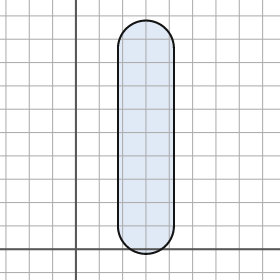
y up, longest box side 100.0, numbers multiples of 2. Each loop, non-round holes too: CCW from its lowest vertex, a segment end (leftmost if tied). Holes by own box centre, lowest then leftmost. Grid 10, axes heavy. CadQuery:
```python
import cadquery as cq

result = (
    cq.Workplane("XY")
    .moveTo(18.0, 10.0)
    .threePointArc((30.0, -2.0), (42.0, 10.0))
    .lineTo(42.0, 86.0)
    .threePointArc((30.0, 98.0), (18.0, 86.0))
    .close()
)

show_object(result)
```